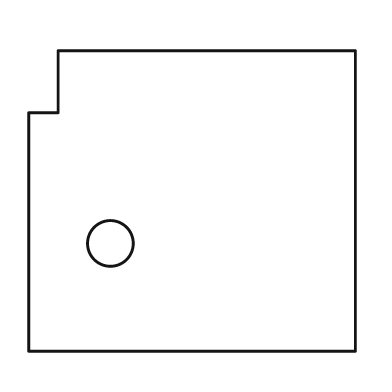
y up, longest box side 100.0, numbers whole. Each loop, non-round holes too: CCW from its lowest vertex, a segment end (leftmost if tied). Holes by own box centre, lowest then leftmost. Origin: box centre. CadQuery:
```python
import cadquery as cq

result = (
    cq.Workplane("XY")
    .moveTo(-50.0, -46.0)
    .lineTo(50.0, -46.0)
    .lineTo(50.0, 46.0)
    .lineTo(-41.0, 46.0)
    .lineTo(-41.0, 27.0)
    .lineTo(-50.0, 27.0)
    .close()
    .moveTo(-25.0, -13.0)
    .circle(7.0)
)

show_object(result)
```